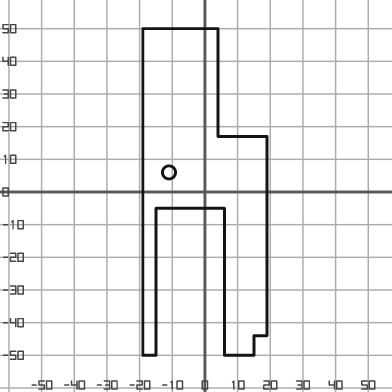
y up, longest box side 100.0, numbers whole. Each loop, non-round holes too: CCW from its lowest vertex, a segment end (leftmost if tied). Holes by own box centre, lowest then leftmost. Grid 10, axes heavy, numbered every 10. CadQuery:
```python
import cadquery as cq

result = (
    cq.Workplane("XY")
    .moveTo(-19.0, -50.0)
    .lineTo(-15.0, -50.0)
    .lineTo(-15.0, -5.0)
    .lineTo(6.0, -5.0)
    .lineTo(6.0, -50.0)
    .lineTo(15.0, -50.0)
    .lineTo(15.0, -44.0)
    .lineTo(19.0, -44.0)
    .lineTo(19.0, 17.0)
    .lineTo(4.0, 17.0)
    .lineTo(4.0, 50.0)
    .lineTo(-19.0, 50.0)
    .close()
    .moveTo(-11.0, 6.0)
    .circle(2.0)
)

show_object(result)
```